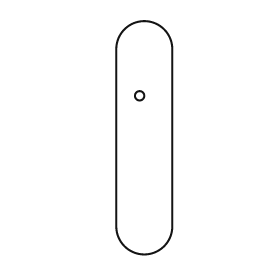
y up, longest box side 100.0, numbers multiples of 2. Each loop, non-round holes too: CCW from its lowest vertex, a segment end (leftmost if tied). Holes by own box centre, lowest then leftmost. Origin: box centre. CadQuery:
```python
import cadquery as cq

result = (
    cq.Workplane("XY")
    .moveTo(-12.0, -38.0)
    .threePointArc((0.0, -50.0), (12.0, -38.0))
    .lineTo(12.0, 38.0)
    .threePointArc((0.0, 50.0), (-12.0, 38.0))
    .close()
    .moveTo(-2.0, 18.0)
    .circle(2.0)
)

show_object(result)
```